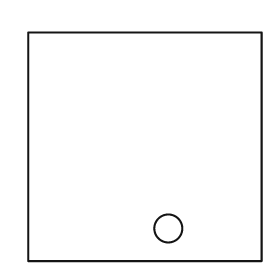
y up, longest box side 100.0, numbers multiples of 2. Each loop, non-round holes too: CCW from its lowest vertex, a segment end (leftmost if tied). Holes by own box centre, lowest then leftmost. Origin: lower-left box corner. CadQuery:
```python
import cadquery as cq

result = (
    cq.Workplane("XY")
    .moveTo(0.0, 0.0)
    .lineTo(100.0, 0.0)
    .lineTo(100.0, 98.0)
    .lineTo(0.0, 98.0)
    .close()
    .moveTo(60.0, 14.0)
    .circle(6.0)
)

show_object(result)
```